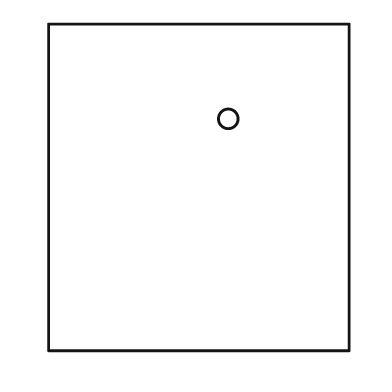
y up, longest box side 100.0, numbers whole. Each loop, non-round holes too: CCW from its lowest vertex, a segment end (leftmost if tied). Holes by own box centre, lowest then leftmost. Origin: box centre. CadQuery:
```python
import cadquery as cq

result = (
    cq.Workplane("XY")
    .moveTo(-46.0, -50.0)
    .lineTo(46.0, -50.0)
    .lineTo(46.0, 50.0)
    .lineTo(-46.0, 50.0)
    .close()
    .moveTo(9.0, 21.0)
    .circle(3.0)
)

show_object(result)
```